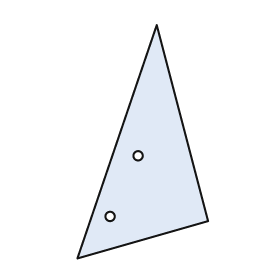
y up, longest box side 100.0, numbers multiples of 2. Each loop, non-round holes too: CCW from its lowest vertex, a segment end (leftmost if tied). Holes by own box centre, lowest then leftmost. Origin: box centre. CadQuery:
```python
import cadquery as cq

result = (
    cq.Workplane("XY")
    .moveTo(-28.0, -50.0)
    .lineTo(28.0, -34.0)
    .lineTo(6.0, 50.0)
    .close()
    .moveTo(-14.0, -32.0)
    .circle(2.0)
    .moveTo(-2.0, -6.0)
    .circle(2.0)
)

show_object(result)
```